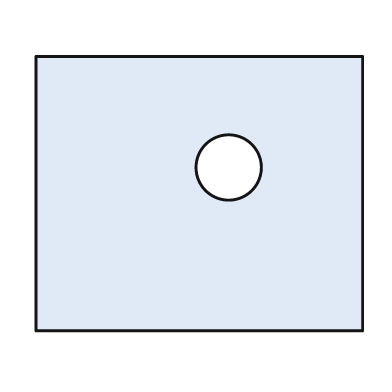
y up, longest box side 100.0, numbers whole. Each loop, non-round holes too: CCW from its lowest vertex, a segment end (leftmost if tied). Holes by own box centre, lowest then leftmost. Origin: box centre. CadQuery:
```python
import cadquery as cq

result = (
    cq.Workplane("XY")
    .moveTo(-50.0, -42.0)
    .lineTo(50.0, -42.0)
    .lineTo(50.0, 42.0)
    .lineTo(-50.0, 42.0)
    .close()
    .moveTo(9.0, 8.0)
    .circle(10.0)
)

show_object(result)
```